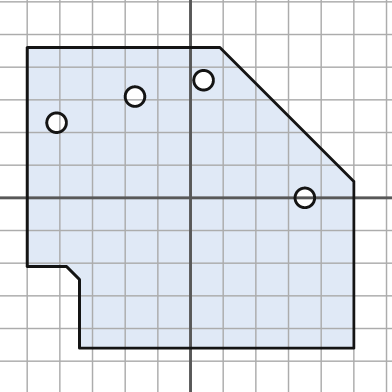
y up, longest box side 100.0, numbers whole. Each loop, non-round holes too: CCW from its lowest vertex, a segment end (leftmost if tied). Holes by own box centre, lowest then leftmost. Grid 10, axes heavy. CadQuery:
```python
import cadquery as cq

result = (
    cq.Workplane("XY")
    .moveTo(-34.0, -46.0)
    .lineTo(50.0, -46.0)
    .lineTo(50.0, 5.0)
    .lineTo(9.0, 46.0)
    .lineTo(-50.0, 46.0)
    .lineTo(-50.0, -21.0)
    .lineTo(-38.0, -21.0)
    .lineTo(-34.0, -25.0)
    .close()
    .moveTo(35.0, 0.0)
    .circle(3.0)
    .moveTo(-41.0, 23.0)
    .circle(3.0)
    .moveTo(-17.0, 31.0)
    .circle(3.0)
    .moveTo(4.0, 36.0)
    .circle(3.0)
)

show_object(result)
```